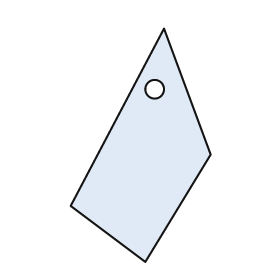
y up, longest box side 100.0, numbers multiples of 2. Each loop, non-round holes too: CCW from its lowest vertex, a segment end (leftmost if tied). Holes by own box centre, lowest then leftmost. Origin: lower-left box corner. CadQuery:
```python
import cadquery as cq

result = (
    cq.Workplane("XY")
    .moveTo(32.0, 0.0)
    .lineTo(60.0, 46.0)
    .lineTo(40.0, 100.0)
    .lineTo(0.0, 24.0)
    .close()
    .moveTo(36.0, 74.0)
    .circle(4.0)
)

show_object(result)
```